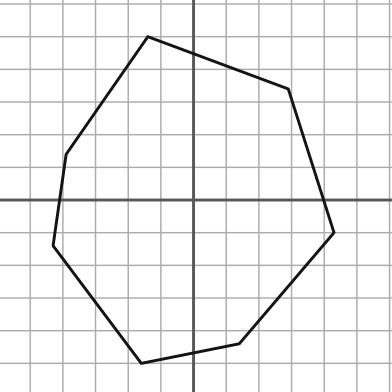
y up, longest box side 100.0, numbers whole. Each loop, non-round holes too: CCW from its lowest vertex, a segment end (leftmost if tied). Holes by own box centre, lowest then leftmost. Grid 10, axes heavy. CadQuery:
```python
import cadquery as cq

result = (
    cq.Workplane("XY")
    .moveTo(-16.0, -50.0)
    .lineTo(14.0, -44.0)
    .lineTo(43.0, -10.0)
    .lineTo(29.0, 34.0)
    .lineTo(-14.0, 50.0)
    .lineTo(-39.0, 14.0)
    .lineTo(-43.0, -14.0)
    .close()
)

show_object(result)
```